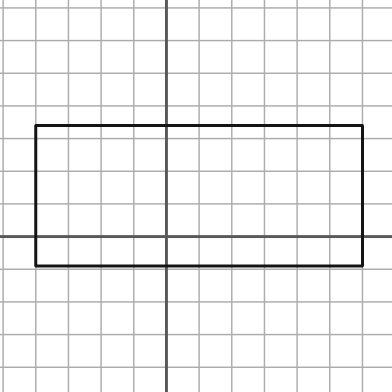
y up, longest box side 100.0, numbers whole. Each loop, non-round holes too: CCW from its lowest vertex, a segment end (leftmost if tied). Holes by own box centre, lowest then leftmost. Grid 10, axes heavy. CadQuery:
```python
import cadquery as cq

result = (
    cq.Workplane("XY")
    .moveTo(-40.0, -9.0)
    .lineTo(60.0, -9.0)
    .lineTo(60.0, 34.0)
    .lineTo(-40.0, 34.0)
    .close()
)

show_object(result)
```